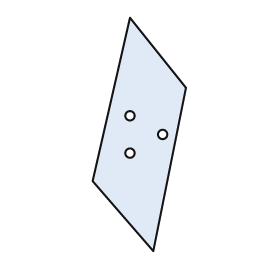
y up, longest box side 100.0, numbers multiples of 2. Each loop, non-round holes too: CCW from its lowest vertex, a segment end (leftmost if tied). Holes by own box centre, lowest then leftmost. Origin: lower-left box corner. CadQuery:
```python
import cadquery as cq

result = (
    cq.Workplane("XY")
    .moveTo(26.0, 0.0)
    .lineTo(40.0, 70.0)
    .lineTo(16.0, 100.0)
    .lineTo(0.0, 30.0)
    .close()
    .moveTo(16.0, 42.0)
    .circle(2.0)
    .moveTo(30.0, 50.0)
    .circle(2.0)
    .moveTo(16.0, 58.0)
    .circle(2.0)
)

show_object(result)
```